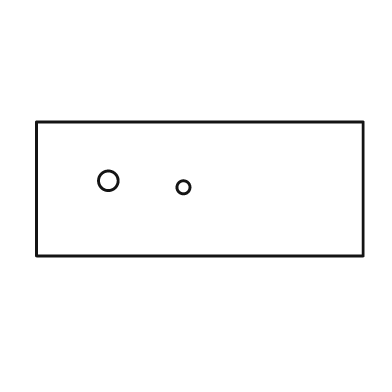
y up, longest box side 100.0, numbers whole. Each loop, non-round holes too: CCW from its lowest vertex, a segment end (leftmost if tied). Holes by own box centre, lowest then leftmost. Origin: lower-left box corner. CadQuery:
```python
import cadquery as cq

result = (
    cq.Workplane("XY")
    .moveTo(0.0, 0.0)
    .lineTo(100.0, 0.0)
    .lineTo(100.0, 41.0)
    .lineTo(0.0, 41.0)
    .close()
    .moveTo(45.0, 21.0)
    .circle(2.0)
    .moveTo(22.0, 23.0)
    .circle(3.0)
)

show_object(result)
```